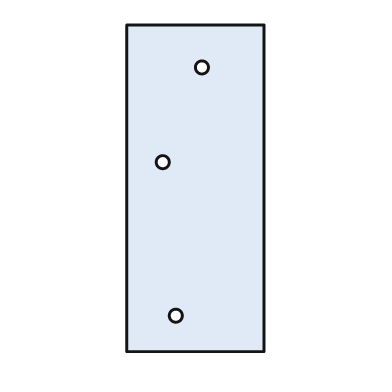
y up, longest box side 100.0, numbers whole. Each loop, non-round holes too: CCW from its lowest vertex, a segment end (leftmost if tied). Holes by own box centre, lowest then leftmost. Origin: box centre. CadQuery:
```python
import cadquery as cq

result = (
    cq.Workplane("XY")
    .moveTo(-21.0, -50.0)
    .lineTo(21.0, -50.0)
    .lineTo(21.0, 50.0)
    .lineTo(-21.0, 50.0)
    .close()
    .moveTo(-6.0, -39.0)
    .circle(2.0)
    .moveTo(-10.0, 8.0)
    .circle(2.0)
    .moveTo(2.0, 37.0)
    .circle(2.0)
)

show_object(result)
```